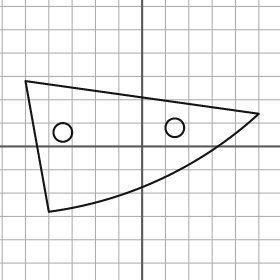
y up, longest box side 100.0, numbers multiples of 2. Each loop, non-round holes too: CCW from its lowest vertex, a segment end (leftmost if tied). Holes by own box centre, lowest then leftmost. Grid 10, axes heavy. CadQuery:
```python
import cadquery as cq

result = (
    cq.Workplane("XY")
    .moveTo(-40.0, -28.0)
    .threePointArc((8.0, -14.0), (50.0, 14.0))
    .lineTo(-50.0, 28.0)
    .close()
    .moveTo(-34.0, 6.0)
    .circle(4.0)
    .moveTo(14.0, 8.0)
    .circle(4.0)
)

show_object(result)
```